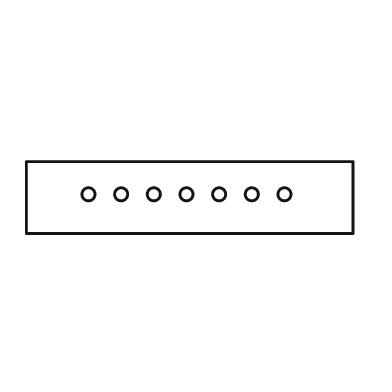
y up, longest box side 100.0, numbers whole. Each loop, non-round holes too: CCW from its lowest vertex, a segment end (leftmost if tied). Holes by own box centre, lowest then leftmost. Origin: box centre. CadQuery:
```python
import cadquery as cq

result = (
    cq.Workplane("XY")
    .moveTo(-50.0, -11.0)
    .lineTo(50.0, -11.0)
    .lineTo(50.0, 11.0)
    .lineTo(-50.0, 11.0)
    .close()
    .moveTo(-31.0, 1.0)
    .circle(2.0)
    .moveTo(-21.0, 1.0)
    .circle(2.0)
    .moveTo(-11.0, 1.0)
    .circle(2.0)
    .moveTo(-1.0, 1.0)
    .circle(2.0)
    .moveTo(9.0, 1.0)
    .circle(2.0)
    .moveTo(19.0, 1.0)
    .circle(2.0)
    .moveTo(29.0, 1.0)
    .circle(2.0)
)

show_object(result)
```